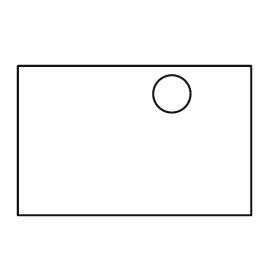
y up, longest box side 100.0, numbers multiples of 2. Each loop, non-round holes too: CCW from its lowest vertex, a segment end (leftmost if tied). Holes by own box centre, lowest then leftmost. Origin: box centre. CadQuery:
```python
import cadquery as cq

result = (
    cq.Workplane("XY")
    .moveTo(-50.0, -32.0)
    .lineTo(50.0, -32.0)
    .lineTo(50.0, 32.0)
    .lineTo(-50.0, 32.0)
    .close()
    .moveTo(16.0, 20.0)
    .circle(8.0)
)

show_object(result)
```